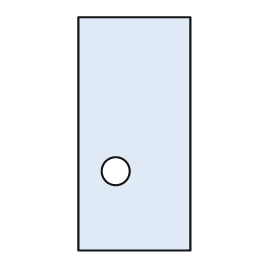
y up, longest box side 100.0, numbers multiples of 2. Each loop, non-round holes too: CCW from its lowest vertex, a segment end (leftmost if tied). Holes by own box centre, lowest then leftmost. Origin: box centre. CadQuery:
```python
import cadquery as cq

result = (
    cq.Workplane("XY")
    .moveTo(-24.0, -50.0)
    .lineTo(24.0, -50.0)
    .lineTo(24.0, 50.0)
    .lineTo(-24.0, 50.0)
    .close()
    .moveTo(-8.0, -16.0)
    .circle(6.0)
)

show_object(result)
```